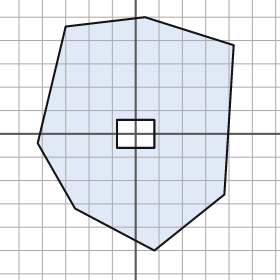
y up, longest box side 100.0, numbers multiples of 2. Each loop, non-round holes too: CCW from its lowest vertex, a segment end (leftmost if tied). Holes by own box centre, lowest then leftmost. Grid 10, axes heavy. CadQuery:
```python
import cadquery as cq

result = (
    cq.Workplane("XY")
    .moveTo(8.0, -50.0)
    .lineTo(38.0, -26.0)
    .lineTo(42.0, 38.0)
    .lineTo(4.0, 50.0)
    .lineTo(-30.0, 46.0)
    .lineTo(-42.0, -4.0)
    .lineTo(-26.0, -32.0)
    .close()
    .moveTo(-8.0, -6.0)
    .lineTo(8.0, -6.0)
    .lineTo(8.0, 6.0)
    .lineTo(-8.0, 6.0)
    .close()
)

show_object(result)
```